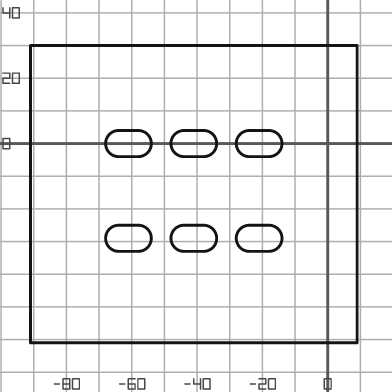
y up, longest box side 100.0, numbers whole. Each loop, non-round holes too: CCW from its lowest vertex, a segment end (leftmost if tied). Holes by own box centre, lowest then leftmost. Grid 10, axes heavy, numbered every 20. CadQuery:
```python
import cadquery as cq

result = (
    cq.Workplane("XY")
    .moveTo(-91.0, -61.0)
    .lineTo(9.0, -61.0)
    .lineTo(9.0, 30.0)
    .lineTo(-91.0, 30.0)
    .close()
    .moveTo(-64.0, -33.0)
    .lineTo(-58.0, -33.0)
    .threePointArc((-54.0, -29.0), (-58.0, -25.0))
    .lineTo(-64.0, -25.0)
    .threePointArc((-68.0, -29.0), (-64.0, -33.0))
    .close()
    .moveTo(-44.0, -33.0)
    .lineTo(-38.0, -33.0)
    .threePointArc((-34.0, -29.0), (-38.0, -25.0))
    .lineTo(-44.0, -25.0)
    .threePointArc((-48.0, -29.0), (-44.0, -33.0))
    .close()
    .moveTo(-24.0, -33.0)
    .lineTo(-18.0, -33.0)
    .threePointArc((-14.0, -29.0), (-18.0, -25.0))
    .lineTo(-24.0, -25.0)
    .threePointArc((-28.0, -29.0), (-24.0, -33.0))
    .close()
    .moveTo(-64.0, -4.0)
    .lineTo(-58.0, -4.0)
    .threePointArc((-54.0, 0.0), (-58.0, 4.0))
    .lineTo(-64.0, 4.0)
    .threePointArc((-68.0, 0.0), (-64.0, -4.0))
    .close()
    .moveTo(-44.0, -4.0)
    .lineTo(-38.0, -4.0)
    .threePointArc((-34.0, 0.0), (-38.0, 4.0))
    .lineTo(-44.0, 4.0)
    .threePointArc((-48.0, 0.0), (-44.0, -4.0))
    .close()
    .moveTo(-24.0, -4.0)
    .lineTo(-18.0, -4.0)
    .threePointArc((-14.0, 0.0), (-18.0, 4.0))
    .lineTo(-24.0, 4.0)
    .threePointArc((-28.0, 0.0), (-24.0, -4.0))
    .close()
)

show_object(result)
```